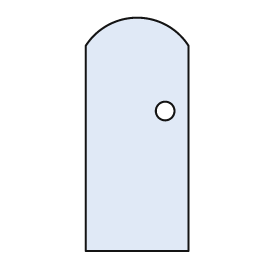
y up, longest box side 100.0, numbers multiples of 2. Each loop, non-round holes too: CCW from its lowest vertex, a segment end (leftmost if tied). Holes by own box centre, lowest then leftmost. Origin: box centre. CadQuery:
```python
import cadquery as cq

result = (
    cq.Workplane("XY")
    .moveTo(-22.0, -50.0)
    .lineTo(22.0, -50.0)
    .lineTo(22.0, 38.0)
    .threePointArc((0.0, 50.0), (-22.0, 38.0))
    .close()
    .moveTo(12.0, 10.0)
    .circle(4.0)
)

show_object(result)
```